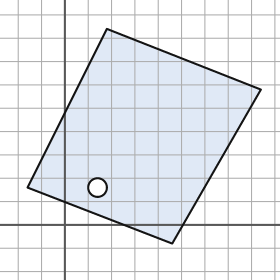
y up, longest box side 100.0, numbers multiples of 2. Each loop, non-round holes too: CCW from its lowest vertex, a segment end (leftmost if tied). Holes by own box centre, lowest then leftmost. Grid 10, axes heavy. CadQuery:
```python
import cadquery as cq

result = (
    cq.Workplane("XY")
    .moveTo(46.0, -8.0)
    .lineTo(84.0, 58.0)
    .lineTo(18.0, 84.0)
    .lineTo(-16.0, 16.0)
    .close()
    .moveTo(14.0, 16.0)
    .circle(4.0)
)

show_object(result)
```